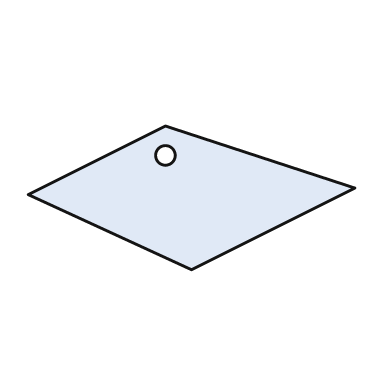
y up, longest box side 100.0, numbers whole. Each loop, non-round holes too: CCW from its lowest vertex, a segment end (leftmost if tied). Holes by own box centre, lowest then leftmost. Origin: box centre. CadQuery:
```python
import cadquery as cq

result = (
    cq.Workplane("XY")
    .moveTo(0.0, -22.0)
    .lineTo(50.0, 3.0)
    .lineTo(-8.0, 22.0)
    .lineTo(-50.0, 1.0)
    .close()
    .moveTo(-8.0, 13.0)
    .circle(3.0)
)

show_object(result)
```